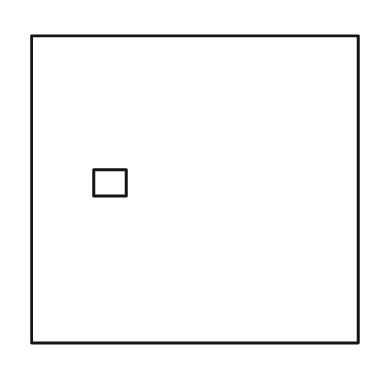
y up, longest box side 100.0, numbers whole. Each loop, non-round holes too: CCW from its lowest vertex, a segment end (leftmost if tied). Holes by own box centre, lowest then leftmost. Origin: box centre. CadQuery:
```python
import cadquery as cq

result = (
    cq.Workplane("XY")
    .moveTo(-50.0, -47.0)
    .lineTo(50.0, -47.0)
    .lineTo(50.0, 47.0)
    .lineTo(-50.0, 47.0)
    .close()
    .moveTo(-31.0, -2.0)
    .lineTo(-21.0, -2.0)
    .lineTo(-21.0, 6.0)
    .lineTo(-31.0, 6.0)
    .close()
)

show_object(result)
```